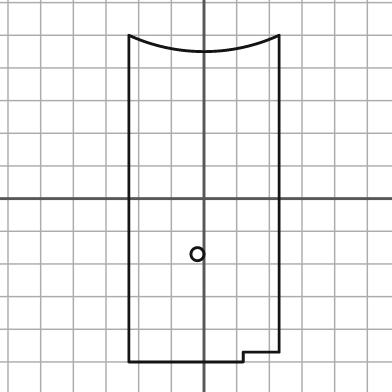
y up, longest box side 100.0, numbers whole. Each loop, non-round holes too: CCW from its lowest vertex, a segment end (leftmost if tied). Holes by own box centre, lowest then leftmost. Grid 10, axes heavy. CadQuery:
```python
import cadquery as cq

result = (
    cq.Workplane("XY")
    .moveTo(-23.0, -50.0)
    .lineTo(12.0, -50.0)
    .lineTo(12.0, -47.0)
    .lineTo(23.0, -47.0)
    .lineTo(23.0, 50.0)
    .threePointArc((0.0, 45.0), (-23.0, 50.0))
    .close()
    .moveTo(-2.0, -17.0)
    .circle(2.0)
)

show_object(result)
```